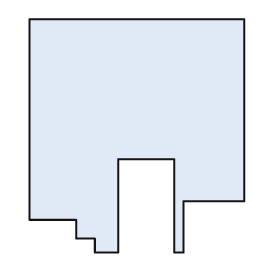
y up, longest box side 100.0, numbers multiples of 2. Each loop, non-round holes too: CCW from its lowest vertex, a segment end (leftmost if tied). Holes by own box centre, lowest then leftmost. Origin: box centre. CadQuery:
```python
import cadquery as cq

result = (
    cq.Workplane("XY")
    .moveTo(-18.0, -50.0)
    .lineTo(-8.0, -50.0)
    .lineTo(-8.0, -10.0)
    .lineTo(16.0, -10.0)
    .lineTo(16.0, -50.0)
    .lineTo(20.0, -50.0)
    .lineTo(20.0, -28.0)
    .lineTo(46.0, -28.0)
    .lineTo(46.0, 50.0)
    .lineTo(-46.0, 50.0)
    .lineTo(-46.0, -36.0)
    .lineTo(-26.0, -36.0)
    .lineTo(-26.0, -44.0)
    .lineTo(-18.0, -44.0)
    .close()
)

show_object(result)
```